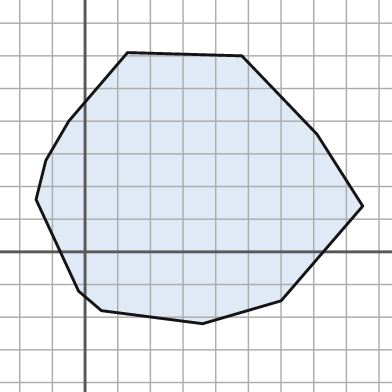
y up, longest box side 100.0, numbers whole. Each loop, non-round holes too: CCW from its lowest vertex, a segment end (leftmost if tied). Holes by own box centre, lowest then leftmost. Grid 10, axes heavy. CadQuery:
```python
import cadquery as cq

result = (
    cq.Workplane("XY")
    .moveTo(36.0, -22.0)
    .lineTo(60.0, -15.0)
    .lineTo(85.0, 14.0)
    .lineTo(71.0, 36.0)
    .lineTo(48.0, 60.0)
    .lineTo(13.0, 61.0)
    .lineTo(-5.0, 40.0)
    .lineTo(-12.0, 28.0)
    .lineTo(-15.0, 16.0)
    .lineTo(-2.0, -12.0)
    .lineTo(5.0, -18.0)
    .close()
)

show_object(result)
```